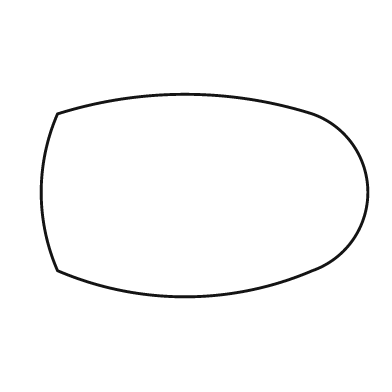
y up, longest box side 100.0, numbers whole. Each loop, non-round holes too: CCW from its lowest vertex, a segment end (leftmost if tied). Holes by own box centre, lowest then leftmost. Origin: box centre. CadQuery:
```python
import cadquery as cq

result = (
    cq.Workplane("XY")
    .moveTo(-45.0, -23.0)
    .threePointArc((-6.0, -31.0), (33.0, -23.0))
    .threePointArc((50.0, 1.0), (33.0, 25.0))
    .threePointArc((-6.0, 31.0), (-45.0, 25.0))
    .threePointArc((-50.0, 1.0), (-45.0, -23.0))
    .close()
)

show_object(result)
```